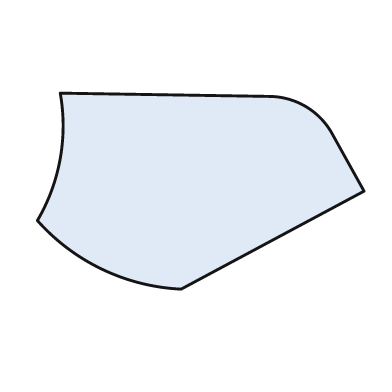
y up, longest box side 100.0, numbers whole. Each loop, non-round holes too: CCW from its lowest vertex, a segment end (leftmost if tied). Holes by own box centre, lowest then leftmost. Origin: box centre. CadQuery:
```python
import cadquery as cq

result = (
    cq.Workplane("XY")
    .moveTo(-6.0, -30.0)
    .lineTo(50.0, 0.0)
    .lineTo(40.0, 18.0)
    .threePointArc((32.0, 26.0), (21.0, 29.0))
    .lineTo(-43.0, 30.0)
    .threePointArc((-43.0, 10.0), (-50.0, -9.0))
    .threePointArc((-30.0, -24.0), (-6.0, -30.0))
    .close()
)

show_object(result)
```